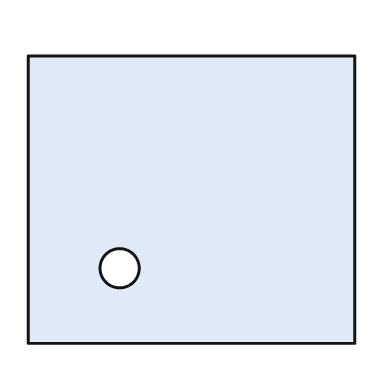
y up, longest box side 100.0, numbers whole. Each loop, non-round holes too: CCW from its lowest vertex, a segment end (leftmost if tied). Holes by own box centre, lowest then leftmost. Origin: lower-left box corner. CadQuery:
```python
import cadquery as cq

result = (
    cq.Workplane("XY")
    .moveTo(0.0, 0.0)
    .lineTo(100.0, 0.0)
    .lineTo(100.0, 88.0)
    .lineTo(0.0, 88.0)
    .close()
    .moveTo(28.0, 23.0)
    .circle(6.0)
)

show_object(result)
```